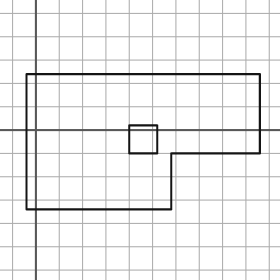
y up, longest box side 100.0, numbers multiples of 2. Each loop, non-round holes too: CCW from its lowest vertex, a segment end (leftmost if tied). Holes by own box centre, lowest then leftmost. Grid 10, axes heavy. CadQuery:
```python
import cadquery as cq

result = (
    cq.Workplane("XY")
    .moveTo(-4.0, -34.0)
    .lineTo(58.0, -34.0)
    .lineTo(58.0, -10.0)
    .lineTo(96.0, -10.0)
    .lineTo(96.0, 24.0)
    .lineTo(-4.0, 24.0)
    .close()
    .moveTo(40.0, -10.0)
    .lineTo(52.0, -10.0)
    .lineTo(52.0, 2.0)
    .lineTo(40.0, 2.0)
    .close()
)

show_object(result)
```